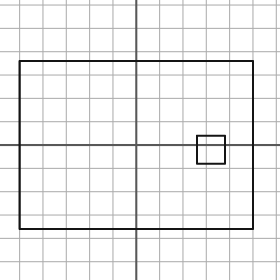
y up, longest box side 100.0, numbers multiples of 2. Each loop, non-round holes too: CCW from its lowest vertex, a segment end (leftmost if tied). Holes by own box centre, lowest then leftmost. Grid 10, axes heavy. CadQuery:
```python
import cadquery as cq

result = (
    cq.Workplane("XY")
    .moveTo(-50.0, -36.0)
    .lineTo(50.0, -36.0)
    .lineTo(50.0, 36.0)
    .lineTo(-50.0, 36.0)
    .close()
    .moveTo(26.0, -8.0)
    .lineTo(38.0, -8.0)
    .lineTo(38.0, 4.0)
    .lineTo(26.0, 4.0)
    .close()
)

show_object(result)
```